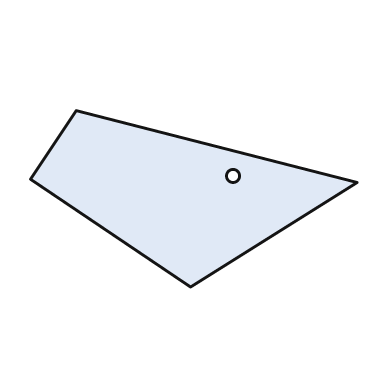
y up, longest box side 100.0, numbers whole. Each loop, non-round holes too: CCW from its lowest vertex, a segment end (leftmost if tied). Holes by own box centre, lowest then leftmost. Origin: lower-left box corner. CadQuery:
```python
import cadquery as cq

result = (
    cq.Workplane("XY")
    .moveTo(49.0, 0.0)
    .lineTo(100.0, 32.0)
    .lineTo(14.0, 54.0)
    .lineTo(0.0, 33.0)
    .close()
    .moveTo(62.0, 34.0)
    .circle(2.0)
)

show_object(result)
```